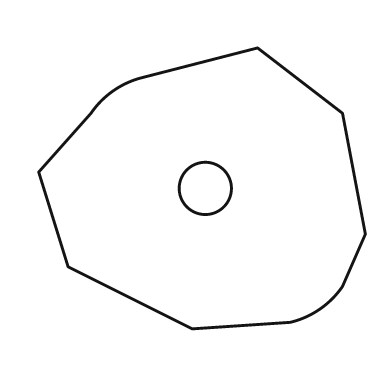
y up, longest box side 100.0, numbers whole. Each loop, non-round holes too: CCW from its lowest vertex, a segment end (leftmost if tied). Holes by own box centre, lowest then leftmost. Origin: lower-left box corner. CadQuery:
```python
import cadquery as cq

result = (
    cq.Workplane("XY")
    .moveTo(47.0, 0.0)
    .lineTo(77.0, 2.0)
    .threePointArc((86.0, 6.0), (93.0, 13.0))
    .lineTo(100.0, 29.0)
    .lineTo(93.0, 66.0)
    .lineTo(67.0, 86.0)
    .lineTo(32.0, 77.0)
    .threePointArc((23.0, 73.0), (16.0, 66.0))
    .lineTo(0.0, 48.0)
    .lineTo(9.0, 19.0)
    .close()
    .moveTo(51.0, 43.0)
    .circle(8.0)
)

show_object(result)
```